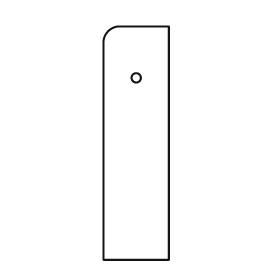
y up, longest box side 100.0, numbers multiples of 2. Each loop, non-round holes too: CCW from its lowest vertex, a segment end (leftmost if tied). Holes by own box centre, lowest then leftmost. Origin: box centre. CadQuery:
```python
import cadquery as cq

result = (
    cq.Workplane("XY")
    .moveTo(-14.0, -50.0)
    .lineTo(14.0, -50.0)
    .lineTo(14.0, 50.0)
    .lineTo(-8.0, 50.0)
    .threePointArc((-12.0, 48.0), (-14.0, 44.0))
    .close()
    .moveTo(0.0, 28.0)
    .circle(2.0)
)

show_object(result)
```